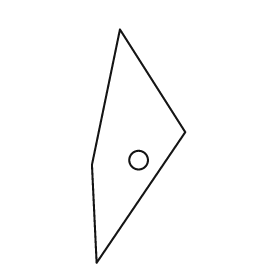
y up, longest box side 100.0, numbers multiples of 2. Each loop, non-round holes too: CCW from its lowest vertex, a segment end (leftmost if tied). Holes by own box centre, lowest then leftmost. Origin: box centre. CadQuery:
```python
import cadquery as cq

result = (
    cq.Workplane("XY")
    .moveTo(-18.0, -50.0)
    .lineTo(20.0, 6.0)
    .lineTo(-8.0, 50.0)
    .lineTo(-20.0, -8.0)
    .close()
    .moveTo(0.0, -6.0)
    .circle(4.0)
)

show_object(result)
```